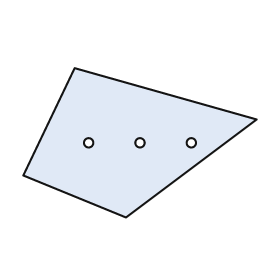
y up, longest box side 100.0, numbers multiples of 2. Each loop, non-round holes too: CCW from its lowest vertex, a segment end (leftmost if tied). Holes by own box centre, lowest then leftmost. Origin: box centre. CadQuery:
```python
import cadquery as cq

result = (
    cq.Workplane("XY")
    .moveTo(-6.0, -32.0)
    .lineTo(50.0, 10.0)
    .lineTo(-28.0, 32.0)
    .lineTo(-50.0, -14.0)
    .close()
    .moveTo(-22.0, 0.0)
    .circle(2.0)
    .moveTo(0.0, 0.0)
    .circle(2.0)
    .moveTo(22.0, 0.0)
    .circle(2.0)
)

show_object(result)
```